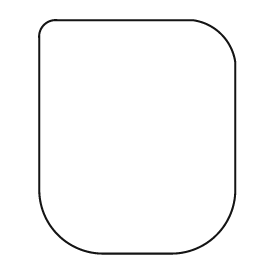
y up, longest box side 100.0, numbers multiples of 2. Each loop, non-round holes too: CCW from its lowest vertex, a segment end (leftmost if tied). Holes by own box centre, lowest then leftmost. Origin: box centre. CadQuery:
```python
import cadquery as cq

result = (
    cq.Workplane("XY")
    .moveTo(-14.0, -50.0)
    .lineTo(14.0, -50.0)
    .threePointArc((34.0, -42.0), (42.0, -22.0))
    .lineTo(42.0, 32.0)
    .threePointArc((36.0, 44.0), (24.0, 50.0))
    .lineTo(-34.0, 50.0)
    .threePointArc((-40.0, 48.0), (-42.0, 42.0))
    .lineTo(-42.0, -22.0)
    .threePointArc((-34.0, -42.0), (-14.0, -50.0))
    .close()
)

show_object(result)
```